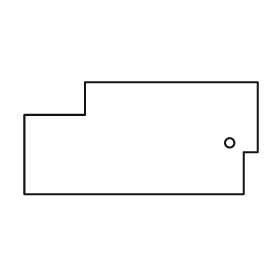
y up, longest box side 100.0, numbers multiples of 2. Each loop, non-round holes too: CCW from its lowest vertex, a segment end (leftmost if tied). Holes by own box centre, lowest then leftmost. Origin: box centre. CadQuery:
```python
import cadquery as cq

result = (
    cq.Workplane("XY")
    .moveTo(-50.0, -24.0)
    .lineTo(44.0, -24.0)
    .lineTo(44.0, -6.0)
    .lineTo(50.0, -6.0)
    .lineTo(50.0, 24.0)
    .lineTo(-24.0, 24.0)
    .lineTo(-24.0, 10.0)
    .lineTo(-50.0, 10.0)
    .close()
    .moveTo(38.0, -2.0)
    .circle(2.0)
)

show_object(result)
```